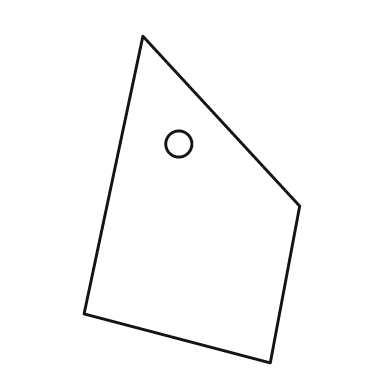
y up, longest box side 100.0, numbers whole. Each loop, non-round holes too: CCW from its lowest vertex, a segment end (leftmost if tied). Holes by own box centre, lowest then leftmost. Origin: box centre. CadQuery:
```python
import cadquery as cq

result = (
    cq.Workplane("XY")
    .moveTo(24.0, -50.0)
    .lineTo(33.0, -2.0)
    .lineTo(-15.0, 50.0)
    .lineTo(-33.0, -35.0)
    .close()
    .moveTo(-4.0, 17.0)
    .circle(4.0)
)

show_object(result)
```